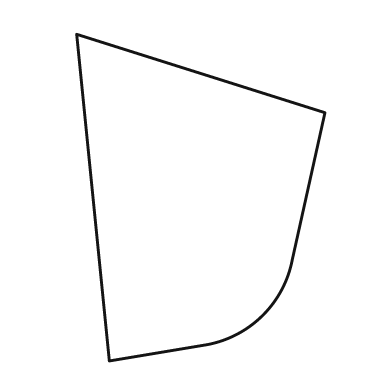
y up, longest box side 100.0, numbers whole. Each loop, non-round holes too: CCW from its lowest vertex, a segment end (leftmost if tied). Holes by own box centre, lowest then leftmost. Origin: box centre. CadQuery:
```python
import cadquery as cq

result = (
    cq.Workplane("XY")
    .moveTo(-28.0, -50.0)
    .lineTo(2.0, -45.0)
    .threePointArc((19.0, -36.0), (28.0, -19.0))
    .lineTo(38.0, 26.0)
    .lineTo(-38.0, 50.0)
    .close()
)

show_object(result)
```